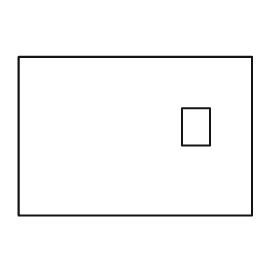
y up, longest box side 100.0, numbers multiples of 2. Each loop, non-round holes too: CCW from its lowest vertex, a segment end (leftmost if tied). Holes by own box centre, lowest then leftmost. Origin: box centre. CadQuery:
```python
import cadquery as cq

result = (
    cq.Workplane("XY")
    .moveTo(-50.0, -34.0)
    .lineTo(50.0, -34.0)
    .lineTo(50.0, 34.0)
    .lineTo(-50.0, 34.0)
    .close()
    .moveTo(20.0, -4.0)
    .lineTo(32.0, -4.0)
    .lineTo(32.0, 12.0)
    .lineTo(20.0, 12.0)
    .close()
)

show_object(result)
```